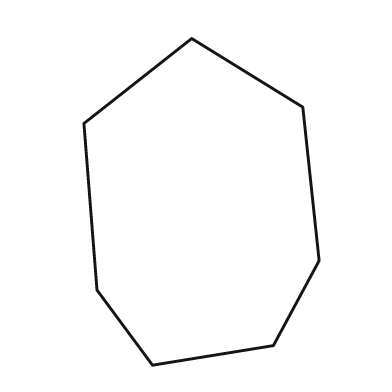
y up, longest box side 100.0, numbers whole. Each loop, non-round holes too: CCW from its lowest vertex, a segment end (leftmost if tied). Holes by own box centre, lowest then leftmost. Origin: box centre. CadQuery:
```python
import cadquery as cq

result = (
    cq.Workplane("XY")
    .moveTo(-15.0, -50.0)
    .lineTo(22.0, -44.0)
    .lineTo(36.0, -18.0)
    .lineTo(31.0, 29.0)
    .lineTo(-3.0, 50.0)
    .lineTo(-36.0, 24.0)
    .lineTo(-32.0, -27.0)
    .close()
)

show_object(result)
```